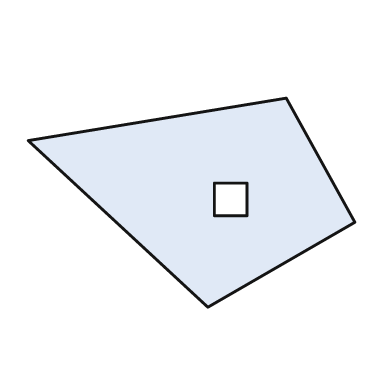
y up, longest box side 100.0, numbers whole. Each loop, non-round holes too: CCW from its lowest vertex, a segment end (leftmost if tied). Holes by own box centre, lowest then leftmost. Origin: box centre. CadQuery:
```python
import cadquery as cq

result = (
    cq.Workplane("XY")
    .moveTo(5.0, -32.0)
    .lineTo(50.0, -6.0)
    .lineTo(29.0, 32.0)
    .lineTo(-50.0, 19.0)
    .close()
    .moveTo(7.0, -4.0)
    .lineTo(17.0, -4.0)
    .lineTo(17.0, 6.0)
    .lineTo(7.0, 6.0)
    .close()
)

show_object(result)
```